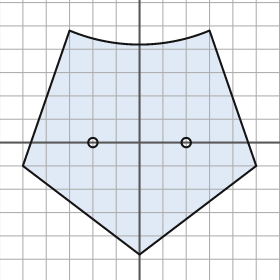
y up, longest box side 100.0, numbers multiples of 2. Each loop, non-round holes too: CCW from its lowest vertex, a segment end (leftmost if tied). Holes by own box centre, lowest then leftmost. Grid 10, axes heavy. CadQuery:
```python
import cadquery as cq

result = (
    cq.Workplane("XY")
    .moveTo(0.0, -48.0)
    .lineTo(50.0, -10.0)
    .lineTo(30.0, 48.0)
    .threePointArc((0.0, 42.0), (-30.0, 48.0))
    .lineTo(-50.0, -10.0)
    .close()
    .moveTo(-20.0, 0.0)
    .circle(2.0)
    .moveTo(20.0, 0.0)
    .circle(2.0)
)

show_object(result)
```